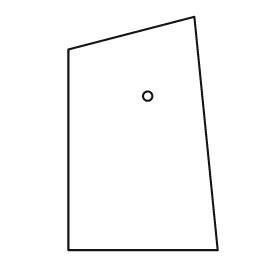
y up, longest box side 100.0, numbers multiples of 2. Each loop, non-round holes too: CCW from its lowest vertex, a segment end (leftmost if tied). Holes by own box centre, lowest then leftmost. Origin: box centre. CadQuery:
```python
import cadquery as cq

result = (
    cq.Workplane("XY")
    .moveTo(-32.0, -50.0)
    .lineTo(32.0, -50.0)
    .lineTo(22.0, 50.0)
    .lineTo(-32.0, 36.0)
    .close()
    .moveTo(2.0, 16.0)
    .circle(2.0)
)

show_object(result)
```